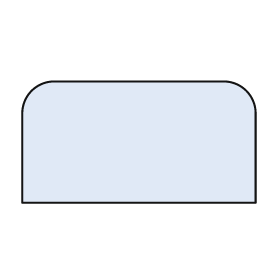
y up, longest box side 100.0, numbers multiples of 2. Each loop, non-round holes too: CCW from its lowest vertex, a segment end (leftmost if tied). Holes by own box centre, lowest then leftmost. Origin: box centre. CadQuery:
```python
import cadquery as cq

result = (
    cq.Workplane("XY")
    .moveTo(-50.0, -26.0)
    .lineTo(50.0, -26.0)
    .lineTo(50.0, 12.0)
    .threePointArc((46.0, 22.0), (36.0, 26.0))
    .lineTo(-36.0, 26.0)
    .threePointArc((-46.0, 22.0), (-50.0, 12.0))
    .close()
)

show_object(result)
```